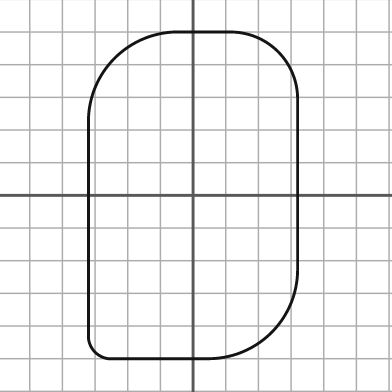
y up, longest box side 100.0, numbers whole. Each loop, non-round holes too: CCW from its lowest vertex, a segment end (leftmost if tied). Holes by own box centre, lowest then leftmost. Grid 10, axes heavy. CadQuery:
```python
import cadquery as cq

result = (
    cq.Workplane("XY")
    .moveTo(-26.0, -50.0)
    .lineTo(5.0, -50.0)
    .threePointArc((24.0, -42.0), (32.0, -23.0))
    .lineTo(32.0, 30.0)
    .threePointArc((26.0, 44.0), (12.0, 50.0))
    .lineTo(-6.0, 50.0)
    .threePointArc((-24.0, 42.0), (-32.0, 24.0))
    .lineTo(-32.0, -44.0)
    .threePointArc((-30.0, -48.0), (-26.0, -50.0))
    .close()
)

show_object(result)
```